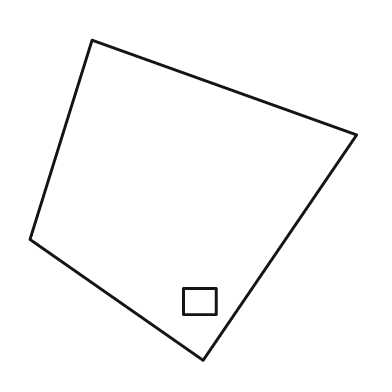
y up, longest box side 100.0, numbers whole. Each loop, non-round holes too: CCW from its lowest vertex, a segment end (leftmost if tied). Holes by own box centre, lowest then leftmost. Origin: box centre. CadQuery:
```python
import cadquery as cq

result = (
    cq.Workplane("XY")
    .moveTo(3.0, -49.0)
    .lineTo(50.0, 20.0)
    .lineTo(-31.0, 49.0)
    .lineTo(-50.0, -12.0)
    .close()
    .moveTo(-3.0, -35.0)
    .lineTo(7.0, -35.0)
    .lineTo(7.0, -27.0)
    .lineTo(-3.0, -27.0)
    .close()
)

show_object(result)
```